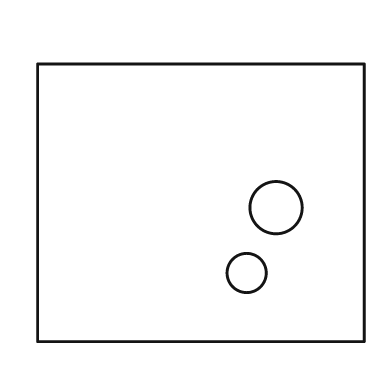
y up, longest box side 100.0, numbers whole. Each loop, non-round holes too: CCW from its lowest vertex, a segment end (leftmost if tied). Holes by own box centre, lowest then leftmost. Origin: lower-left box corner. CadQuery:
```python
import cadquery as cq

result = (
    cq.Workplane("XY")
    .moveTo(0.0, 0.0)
    .lineTo(100.0, 0.0)
    .lineTo(100.0, 85.0)
    .lineTo(0.0, 85.0)
    .close()
    .moveTo(64.0, 21.0)
    .circle(6.0)
    .moveTo(73.0, 41.0)
    .circle(8.0)
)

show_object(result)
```